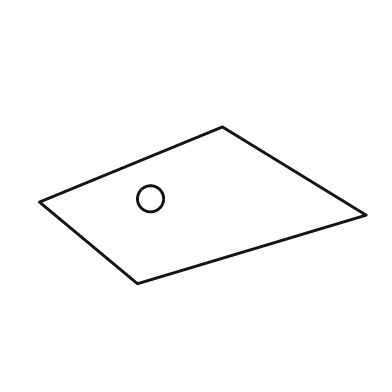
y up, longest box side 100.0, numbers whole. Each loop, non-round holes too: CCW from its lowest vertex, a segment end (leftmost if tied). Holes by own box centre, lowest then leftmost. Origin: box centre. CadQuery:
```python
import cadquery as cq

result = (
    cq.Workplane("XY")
    .moveTo(-20.0, -24.0)
    .lineTo(50.0, -3.0)
    .lineTo(6.0, 24.0)
    .lineTo(-50.0, 1.0)
    .close()
    .moveTo(-16.0, 2.0)
    .circle(4.0)
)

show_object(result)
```